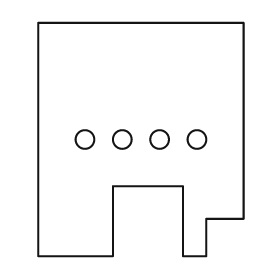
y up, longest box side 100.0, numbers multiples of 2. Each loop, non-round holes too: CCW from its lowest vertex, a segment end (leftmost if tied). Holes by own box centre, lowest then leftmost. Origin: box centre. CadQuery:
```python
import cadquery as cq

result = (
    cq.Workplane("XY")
    .moveTo(-44.0, -50.0)
    .lineTo(-12.0, -50.0)
    .lineTo(-12.0, -20.0)
    .lineTo(18.0, -20.0)
    .lineTo(18.0, -50.0)
    .lineTo(28.0, -50.0)
    .lineTo(28.0, -34.0)
    .lineTo(44.0, -34.0)
    .lineTo(44.0, 50.0)
    .lineTo(-44.0, 50.0)
    .close()
    .moveTo(-24.0, 0.0)
    .circle(4.0)
    .moveTo(-8.0, 0.0)
    .circle(4.0)
    .moveTo(8.0, 0.0)
    .circle(4.0)
    .moveTo(24.0, 0.0)
    .circle(4.0)
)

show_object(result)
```